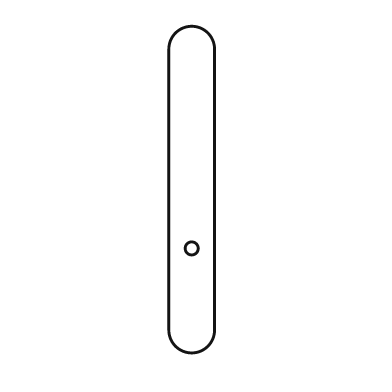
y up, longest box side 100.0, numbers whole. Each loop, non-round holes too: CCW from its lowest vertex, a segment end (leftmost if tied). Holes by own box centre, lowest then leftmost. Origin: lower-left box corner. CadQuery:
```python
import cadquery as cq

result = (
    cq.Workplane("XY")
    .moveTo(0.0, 7.0)
    .threePointArc((7.0, 0.0), (14.0, 7.0))
    .lineTo(14.0, 93.0)
    .threePointArc((7.0, 100.0), (0.0, 93.0))
    .close()
    .moveTo(7.0, 32.0)
    .circle(2.0)
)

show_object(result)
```